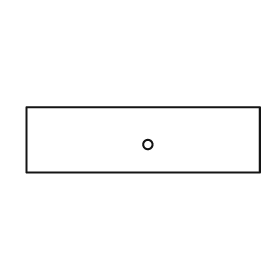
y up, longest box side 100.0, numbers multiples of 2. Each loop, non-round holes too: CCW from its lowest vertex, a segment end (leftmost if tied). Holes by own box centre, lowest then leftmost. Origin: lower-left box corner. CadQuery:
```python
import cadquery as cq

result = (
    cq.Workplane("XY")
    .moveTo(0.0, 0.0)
    .lineTo(100.0, 0.0)
    .lineTo(100.0, 28.0)
    .lineTo(0.0, 28.0)
    .close()
    .moveTo(52.0, 12.0)
    .circle(2.0)
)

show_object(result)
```